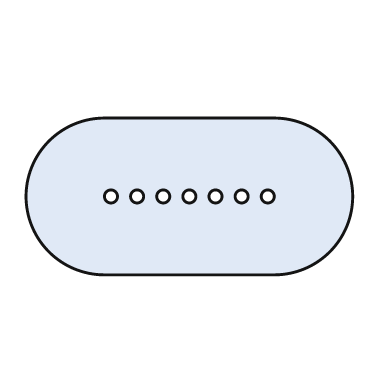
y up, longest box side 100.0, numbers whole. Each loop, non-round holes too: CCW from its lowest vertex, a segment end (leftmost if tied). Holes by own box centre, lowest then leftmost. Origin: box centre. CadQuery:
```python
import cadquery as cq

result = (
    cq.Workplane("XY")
    .moveTo(-26.0, -24.0)
    .lineTo(26.0, -24.0)
    .threePointArc((50.0, 0.0), (26.0, 24.0))
    .lineTo(-26.0, 24.0)
    .threePointArc((-50.0, 0.0), (-26.0, -24.0))
    .close()
    .moveTo(-24.0, 0.0)
    .circle(2.0)
    .moveTo(-16.0, 0.0)
    .circle(2.0)
    .moveTo(-8.0, 0.0)
    .circle(2.0)
    .moveTo(0.0, 0.0)
    .circle(2.0)
    .moveTo(8.0, 0.0)
    .circle(2.0)
    .moveTo(16.0, 0.0)
    .circle(2.0)
    .moveTo(24.0, 0.0)
    .circle(2.0)
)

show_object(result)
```